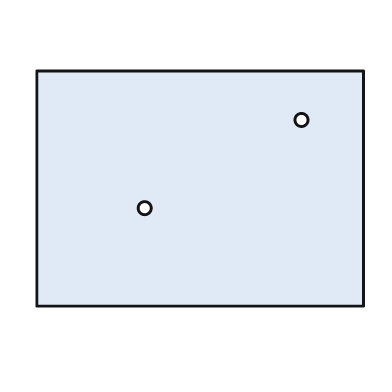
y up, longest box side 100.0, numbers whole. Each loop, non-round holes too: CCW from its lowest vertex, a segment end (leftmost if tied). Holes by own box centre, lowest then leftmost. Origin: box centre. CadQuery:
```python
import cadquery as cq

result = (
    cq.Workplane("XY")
    .moveTo(-50.0, -36.0)
    .lineTo(50.0, -36.0)
    .lineTo(50.0, 36.0)
    .lineTo(-50.0, 36.0)
    .close()
    .moveTo(-17.0, -6.0)
    .circle(2.0)
    .moveTo(31.0, 21.0)
    .circle(2.0)
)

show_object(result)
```